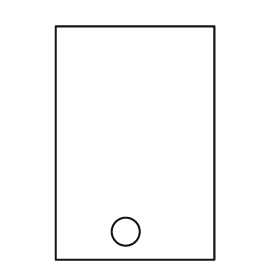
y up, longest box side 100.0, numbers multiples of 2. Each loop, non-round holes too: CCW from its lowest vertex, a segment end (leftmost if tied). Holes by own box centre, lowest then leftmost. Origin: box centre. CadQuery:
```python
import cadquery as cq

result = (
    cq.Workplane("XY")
    .moveTo(-34.0, -50.0)
    .lineTo(34.0, -50.0)
    .lineTo(34.0, 50.0)
    .lineTo(-34.0, 50.0)
    .close()
    .moveTo(-4.0, -38.0)
    .circle(6.0)
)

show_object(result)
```